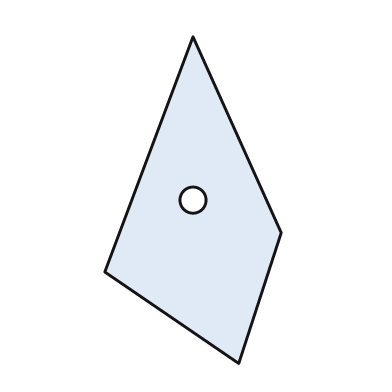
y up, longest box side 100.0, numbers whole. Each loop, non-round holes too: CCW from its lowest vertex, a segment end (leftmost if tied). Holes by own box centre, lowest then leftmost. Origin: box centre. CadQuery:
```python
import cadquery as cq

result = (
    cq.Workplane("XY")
    .moveTo(14.0, -50.0)
    .lineTo(27.0, -10.0)
    .lineTo(0.0, 50.0)
    .lineTo(-27.0, -22.0)
    .close()
    .moveTo(0.0, 0.0)
    .circle(4.0)
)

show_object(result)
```